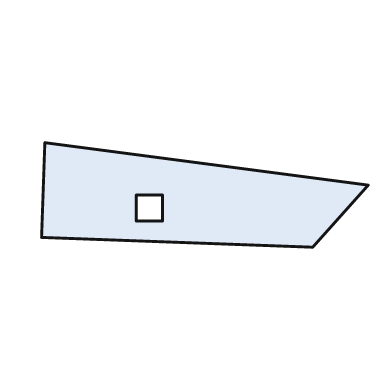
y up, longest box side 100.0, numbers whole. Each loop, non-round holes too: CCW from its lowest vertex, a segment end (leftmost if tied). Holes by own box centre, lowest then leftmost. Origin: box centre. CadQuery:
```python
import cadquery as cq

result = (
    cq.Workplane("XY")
    .moveTo(33.0, -16.0)
    .lineTo(50.0, 3.0)
    .lineTo(-49.0, 16.0)
    .lineTo(-50.0, -13.0)
    .close()
    .moveTo(-21.0, -8.0)
    .lineTo(-13.0, -8.0)
    .lineTo(-13.0, 0.0)
    .lineTo(-21.0, 0.0)
    .close()
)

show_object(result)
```